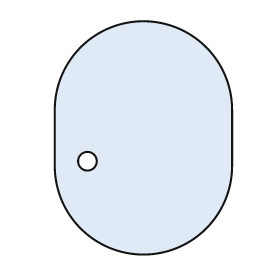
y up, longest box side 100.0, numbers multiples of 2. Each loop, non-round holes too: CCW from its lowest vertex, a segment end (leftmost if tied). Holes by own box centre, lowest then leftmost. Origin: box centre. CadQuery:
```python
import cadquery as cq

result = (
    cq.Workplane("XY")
    .moveTo(-38.0, -12.0)
    .threePointArc((0.0, -50.0), (38.0, -12.0))
    .lineTo(38.0, 12.0)
    .threePointArc((0.0, 50.0), (-38.0, 12.0))
    .close()
    .moveTo(-24.0, -10.0)
    .circle(4.0)
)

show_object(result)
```